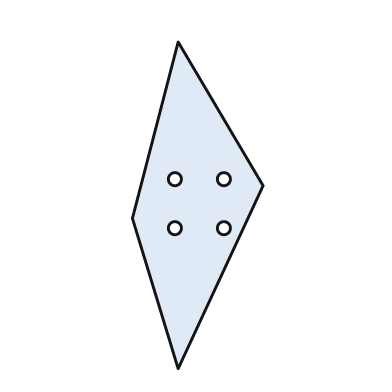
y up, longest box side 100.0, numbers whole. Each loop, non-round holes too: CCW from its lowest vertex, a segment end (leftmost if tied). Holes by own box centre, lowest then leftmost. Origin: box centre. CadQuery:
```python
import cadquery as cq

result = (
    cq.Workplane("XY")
    .moveTo(-6.0, -50.0)
    .lineTo(20.0, 6.0)
    .lineTo(-6.0, 50.0)
    .lineTo(-20.0, -4.0)
    .close()
    .moveTo(-7.0, -7.0)
    .circle(2.0)
    .moveTo(8.0, -7.0)
    .circle(2.0)
    .moveTo(-7.0, 8.0)
    .circle(2.0)
    .moveTo(8.0, 8.0)
    .circle(2.0)
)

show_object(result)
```